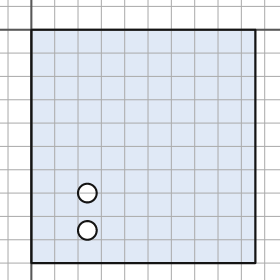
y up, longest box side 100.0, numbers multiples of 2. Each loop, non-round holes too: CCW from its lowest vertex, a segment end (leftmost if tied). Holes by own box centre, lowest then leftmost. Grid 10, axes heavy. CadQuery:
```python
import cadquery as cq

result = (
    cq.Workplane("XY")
    .moveTo(0.0, -100.0)
    .lineTo(96.0, -100.0)
    .lineTo(96.0, 0.0)
    .lineTo(0.0, 0.0)
    .close()
    .moveTo(24.0, -86.0)
    .circle(4.0)
    .moveTo(24.0, -70.0)
    .circle(4.0)
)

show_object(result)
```